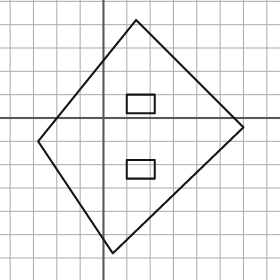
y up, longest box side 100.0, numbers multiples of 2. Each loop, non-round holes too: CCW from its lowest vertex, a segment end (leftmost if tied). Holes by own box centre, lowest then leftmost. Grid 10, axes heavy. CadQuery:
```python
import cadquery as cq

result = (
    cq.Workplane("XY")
    .moveTo(4.0, -58.0)
    .lineTo(60.0, -4.0)
    .lineTo(14.0, 42.0)
    .lineTo(-28.0, -10.0)
    .close()
    .moveTo(10.0, -26.0)
    .lineTo(22.0, -26.0)
    .lineTo(22.0, -18.0)
    .lineTo(10.0, -18.0)
    .close()
    .moveTo(10.0, 2.0)
    .lineTo(22.0, 2.0)
    .lineTo(22.0, 10.0)
    .lineTo(10.0, 10.0)
    .close()
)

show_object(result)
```